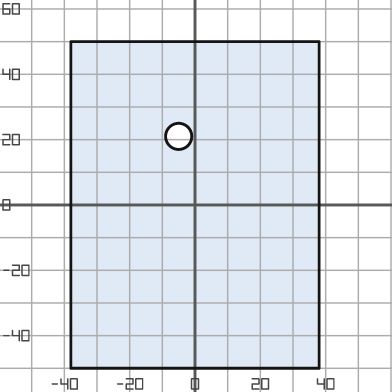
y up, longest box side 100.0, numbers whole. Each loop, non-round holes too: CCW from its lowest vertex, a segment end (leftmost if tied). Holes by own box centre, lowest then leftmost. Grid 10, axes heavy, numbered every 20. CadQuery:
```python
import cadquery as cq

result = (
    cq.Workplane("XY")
    .moveTo(-38.0, -50.0)
    .lineTo(38.0, -50.0)
    .lineTo(38.0, 50.0)
    .lineTo(-38.0, 50.0)
    .close()
    .moveTo(-5.0, 21.0)
    .circle(4.0)
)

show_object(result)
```